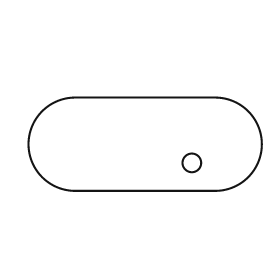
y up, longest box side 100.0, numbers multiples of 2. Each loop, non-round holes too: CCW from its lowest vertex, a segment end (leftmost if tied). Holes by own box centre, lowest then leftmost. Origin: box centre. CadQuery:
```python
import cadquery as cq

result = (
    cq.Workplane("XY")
    .moveTo(-30.0, -20.0)
    .lineTo(30.0, -20.0)
    .threePointArc((50.0, 0.0), (30.0, 20.0))
    .lineTo(-30.0, 20.0)
    .threePointArc((-50.0, 0.0), (-30.0, -20.0))
    .close()
    .moveTo(20.0, -8.0)
    .circle(4.0)
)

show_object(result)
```